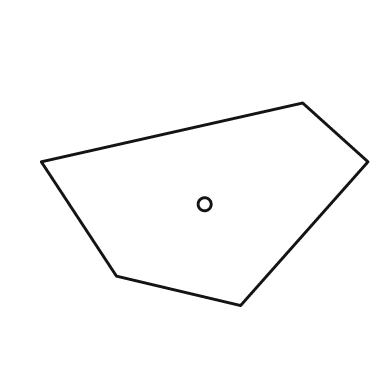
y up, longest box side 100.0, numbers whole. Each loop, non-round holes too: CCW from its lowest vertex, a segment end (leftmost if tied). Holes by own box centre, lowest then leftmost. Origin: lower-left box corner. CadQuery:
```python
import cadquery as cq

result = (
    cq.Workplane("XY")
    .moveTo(61.0, 0.0)
    .lineTo(100.0, 44.0)
    .lineTo(80.0, 62.0)
    .lineTo(0.0, 44.0)
    .lineTo(23.0, 9.0)
    .close()
    .moveTo(50.0, 31.0)
    .circle(2.0)
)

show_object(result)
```